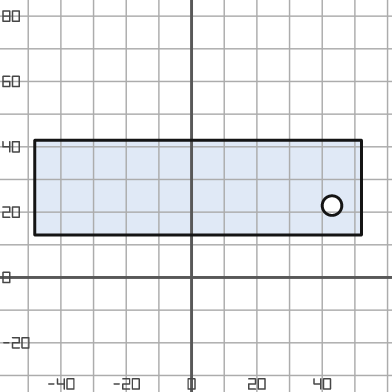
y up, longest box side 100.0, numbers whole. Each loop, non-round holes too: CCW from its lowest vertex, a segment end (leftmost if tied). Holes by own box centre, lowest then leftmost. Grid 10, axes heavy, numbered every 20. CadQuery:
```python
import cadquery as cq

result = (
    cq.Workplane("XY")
    .moveTo(-48.0, 13.0)
    .lineTo(52.0, 13.0)
    .lineTo(52.0, 42.0)
    .lineTo(-48.0, 42.0)
    .close()
    .moveTo(43.0, 22.0)
    .circle(3.0)
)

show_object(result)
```